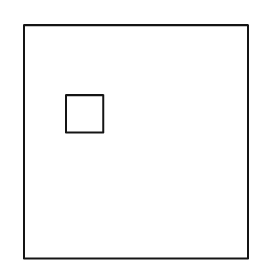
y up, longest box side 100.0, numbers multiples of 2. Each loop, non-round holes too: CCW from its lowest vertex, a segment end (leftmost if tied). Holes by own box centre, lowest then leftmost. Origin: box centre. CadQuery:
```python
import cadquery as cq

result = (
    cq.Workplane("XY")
    .moveTo(-48.0, -50.0)
    .lineTo(48.0, -50.0)
    .lineTo(48.0, 50.0)
    .lineTo(-48.0, 50.0)
    .close()
    .moveTo(-30.0, 4.0)
    .lineTo(-14.0, 4.0)
    .lineTo(-14.0, 20.0)
    .lineTo(-30.0, 20.0)
    .close()
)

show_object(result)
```